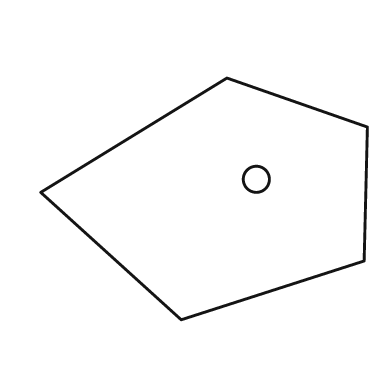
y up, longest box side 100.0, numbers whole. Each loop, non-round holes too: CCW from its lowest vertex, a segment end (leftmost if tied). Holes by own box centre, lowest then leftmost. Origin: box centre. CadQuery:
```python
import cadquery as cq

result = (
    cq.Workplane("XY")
    .moveTo(-7.0, -37.0)
    .lineTo(49.0, -19.0)
    .lineTo(50.0, 22.0)
    .lineTo(7.0, 37.0)
    .lineTo(-50.0, 2.0)
    .close()
    .moveTo(16.0, 6.0)
    .circle(4.0)
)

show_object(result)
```